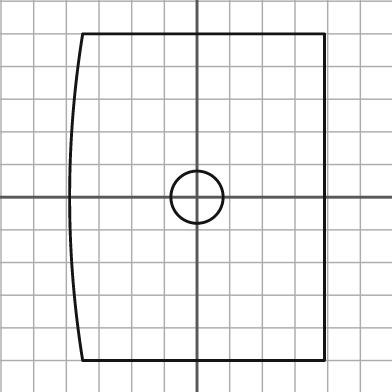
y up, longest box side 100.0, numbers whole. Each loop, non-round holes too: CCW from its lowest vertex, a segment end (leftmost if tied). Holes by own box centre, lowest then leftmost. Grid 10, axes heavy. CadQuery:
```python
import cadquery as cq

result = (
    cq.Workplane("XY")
    .moveTo(-35.0, -50.0)
    .lineTo(39.0, -50.0)
    .lineTo(39.0, 50.0)
    .lineTo(-35.0, 50.0)
    .threePointArc((-39.0, 0.0), (-35.0, -50.0))
    .close()
    .moveTo(0.0, 0.0)
    .circle(8.0)
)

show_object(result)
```